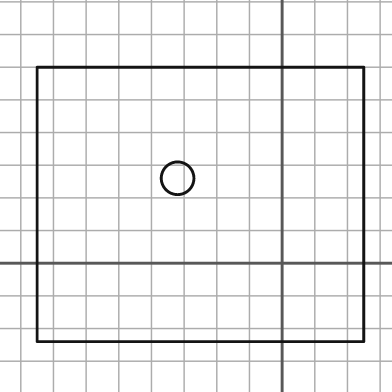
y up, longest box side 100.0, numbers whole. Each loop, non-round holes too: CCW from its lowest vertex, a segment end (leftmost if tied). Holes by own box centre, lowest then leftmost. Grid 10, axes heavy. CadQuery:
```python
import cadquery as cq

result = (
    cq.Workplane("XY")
    .moveTo(-75.0, -24.0)
    .lineTo(25.0, -24.0)
    .lineTo(25.0, 60.0)
    .lineTo(-75.0, 60.0)
    .close()
    .moveTo(-32.0, 26.0)
    .circle(5.0)
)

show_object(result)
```